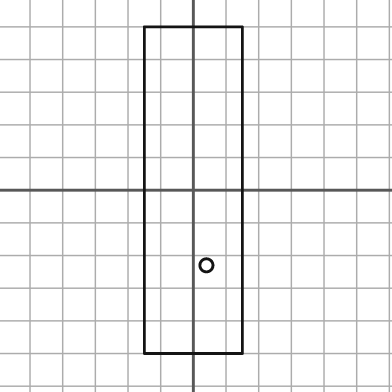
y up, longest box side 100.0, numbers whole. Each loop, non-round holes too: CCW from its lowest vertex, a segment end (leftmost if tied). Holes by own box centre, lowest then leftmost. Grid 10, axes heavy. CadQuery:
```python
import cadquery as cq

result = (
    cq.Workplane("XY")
    .moveTo(-15.0, -50.0)
    .lineTo(15.0, -50.0)
    .lineTo(15.0, 50.0)
    .lineTo(-15.0, 50.0)
    .close()
    .moveTo(4.0, -23.0)
    .circle(2.0)
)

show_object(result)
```